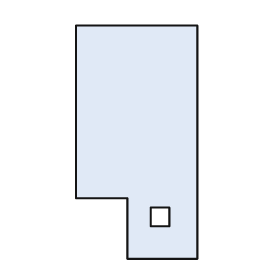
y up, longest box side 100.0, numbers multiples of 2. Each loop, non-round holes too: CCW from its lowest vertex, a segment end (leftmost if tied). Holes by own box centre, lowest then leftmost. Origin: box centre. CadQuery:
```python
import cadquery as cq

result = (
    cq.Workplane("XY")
    .moveTo(-4.0, -50.0)
    .lineTo(26.0, -50.0)
    .lineTo(26.0, 50.0)
    .lineTo(-26.0, 50.0)
    .lineTo(-26.0, -24.0)
    .lineTo(-4.0, -24.0)
    .close()
    .moveTo(6.0, -36.0)
    .lineTo(14.0, -36.0)
    .lineTo(14.0, -28.0)
    .lineTo(6.0, -28.0)
    .close()
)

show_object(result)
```